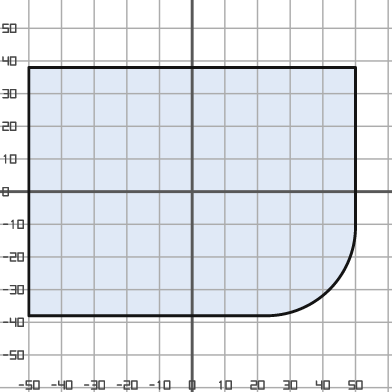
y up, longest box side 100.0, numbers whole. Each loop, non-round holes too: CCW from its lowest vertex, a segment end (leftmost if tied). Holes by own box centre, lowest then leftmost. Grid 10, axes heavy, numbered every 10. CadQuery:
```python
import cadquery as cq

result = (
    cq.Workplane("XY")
    .moveTo(-50.0, -38.0)
    .lineTo(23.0, -38.0)
    .threePointArc((42.0, -30.0), (50.0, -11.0))
    .lineTo(50.0, 38.0)
    .lineTo(-50.0, 38.0)
    .close()
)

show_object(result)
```